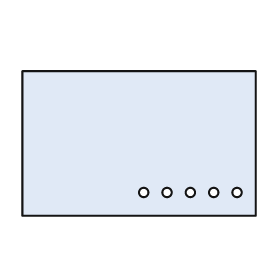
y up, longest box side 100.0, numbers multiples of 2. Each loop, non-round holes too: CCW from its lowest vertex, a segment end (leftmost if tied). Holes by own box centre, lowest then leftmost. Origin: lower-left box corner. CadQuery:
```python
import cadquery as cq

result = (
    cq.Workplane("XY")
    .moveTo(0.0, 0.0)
    .lineTo(100.0, 0.0)
    .lineTo(100.0, 62.0)
    .lineTo(0.0, 62.0)
    .close()
    .moveTo(52.0, 10.0)
    .circle(2.0)
    .moveTo(62.0, 10.0)
    .circle(2.0)
    .moveTo(72.0, 10.0)
    .circle(2.0)
    .moveTo(82.0, 10.0)
    .circle(2.0)
    .moveTo(92.0, 10.0)
    .circle(2.0)
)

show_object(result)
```